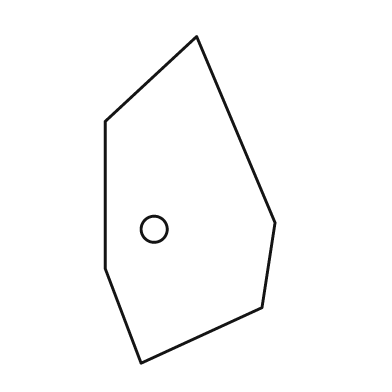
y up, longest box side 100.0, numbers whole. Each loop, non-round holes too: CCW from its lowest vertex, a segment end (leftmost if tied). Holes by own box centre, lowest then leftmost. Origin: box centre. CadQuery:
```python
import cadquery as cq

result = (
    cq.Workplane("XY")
    .moveTo(-15.0, -50.0)
    .lineTo(22.0, -33.0)
    .lineTo(26.0, -7.0)
    .lineTo(2.0, 50.0)
    .lineTo(-26.0, 24.0)
    .lineTo(-26.0, -21.0)
    .close()
    .moveTo(-11.0, -9.0)
    .circle(4.0)
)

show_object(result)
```